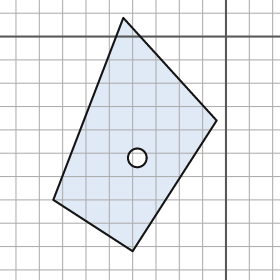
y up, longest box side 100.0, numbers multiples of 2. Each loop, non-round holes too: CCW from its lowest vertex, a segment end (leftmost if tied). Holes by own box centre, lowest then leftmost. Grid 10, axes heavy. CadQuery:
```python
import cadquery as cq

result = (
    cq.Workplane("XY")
    .moveTo(-40.0, -92.0)
    .lineTo(-4.0, -36.0)
    .lineTo(-44.0, 8.0)
    .lineTo(-74.0, -70.0)
    .close()
    .moveTo(-38.0, -52.0)
    .circle(4.0)
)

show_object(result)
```